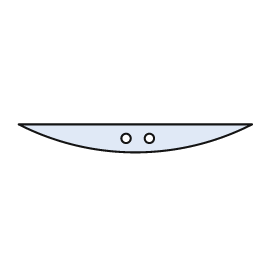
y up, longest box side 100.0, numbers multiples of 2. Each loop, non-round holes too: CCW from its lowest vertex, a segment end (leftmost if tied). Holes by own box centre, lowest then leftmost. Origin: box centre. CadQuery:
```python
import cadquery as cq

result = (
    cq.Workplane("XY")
    .moveTo(-50.0, 6.0)
    .threePointArc((0.0, -6.0), (50.0, 6.0))
    .close()
    .moveTo(-4.0, 0.0)
    .circle(2.0)
    .moveTo(6.0, 0.0)
    .circle(2.0)
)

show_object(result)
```